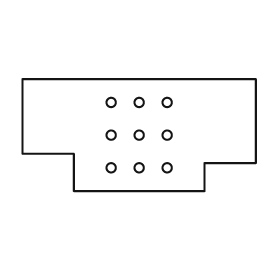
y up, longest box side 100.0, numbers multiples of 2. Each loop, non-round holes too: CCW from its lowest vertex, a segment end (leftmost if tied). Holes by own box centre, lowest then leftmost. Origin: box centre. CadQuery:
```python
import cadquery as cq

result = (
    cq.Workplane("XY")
    .moveTo(-28.0, -24.0)
    .lineTo(28.0, -24.0)
    .lineTo(28.0, -12.0)
    .lineTo(50.0, -12.0)
    .lineTo(50.0, 24.0)
    .lineTo(-50.0, 24.0)
    .lineTo(-50.0, -8.0)
    .lineTo(-28.0, -8.0)
    .close()
    .moveTo(-12.0, -14.0)
    .circle(2.0)
    .moveTo(0.0, -14.0)
    .circle(2.0)
    .moveTo(12.0, -14.0)
    .circle(2.0)
    .moveTo(-12.0, 0.0)
    .circle(2.0)
    .moveTo(0.0, 0.0)
    .circle(2.0)
    .moveTo(12.0, 0.0)
    .circle(2.0)
    .moveTo(-12.0, 14.0)
    .circle(2.0)
    .moveTo(0.0, 14.0)
    .circle(2.0)
    .moveTo(12.0, 14.0)
    .circle(2.0)
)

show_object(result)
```